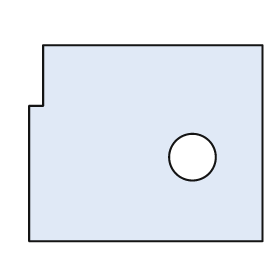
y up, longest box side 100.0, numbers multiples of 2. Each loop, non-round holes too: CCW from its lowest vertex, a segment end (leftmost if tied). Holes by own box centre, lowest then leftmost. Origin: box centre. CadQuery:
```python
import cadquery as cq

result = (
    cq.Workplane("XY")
    .moveTo(-50.0, -42.0)
    .lineTo(50.0, -42.0)
    .lineTo(50.0, 42.0)
    .lineTo(-44.0, 42.0)
    .lineTo(-44.0, 16.0)
    .lineTo(-50.0, 16.0)
    .close()
    .moveTo(20.0, -6.0)
    .circle(10.0)
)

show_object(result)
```